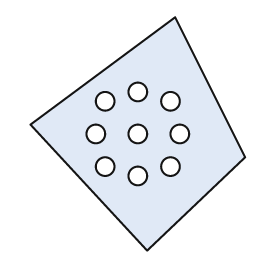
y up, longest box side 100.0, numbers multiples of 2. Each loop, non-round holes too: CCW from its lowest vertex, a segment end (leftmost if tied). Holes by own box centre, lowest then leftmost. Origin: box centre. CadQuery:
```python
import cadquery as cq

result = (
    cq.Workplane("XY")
    .moveTo(4.0, -50.0)
    .lineTo(46.0, -10.0)
    .lineTo(16.0, 50.0)
    .lineTo(-46.0, 4.0)
    .close()
    .moveTo(0.0, -18.0)
    .circle(4.0)
    .moveTo(-14.0, -14.0)
    .circle(4.0)
    .moveTo(14.0, -14.0)
    .circle(4.0)
    .moveTo(-18.0, 0.0)
    .circle(4.0)
    .moveTo(0.0, 0.0)
    .circle(4.0)
    .moveTo(18.0, 0.0)
    .circle(4.0)
    .moveTo(-14.0, 14.0)
    .circle(4.0)
    .moveTo(14.0, 14.0)
    .circle(4.0)
    .moveTo(0.0, 18.0)
    .circle(4.0)
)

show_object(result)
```